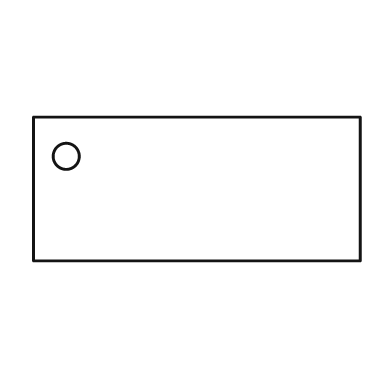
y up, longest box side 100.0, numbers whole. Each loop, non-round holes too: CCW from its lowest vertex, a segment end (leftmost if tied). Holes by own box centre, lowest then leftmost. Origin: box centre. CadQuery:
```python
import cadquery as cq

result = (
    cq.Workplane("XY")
    .moveTo(-50.0, -22.0)
    .lineTo(50.0, -22.0)
    .lineTo(50.0, 22.0)
    .lineTo(-50.0, 22.0)
    .close()
    .moveTo(-40.0, 10.0)
    .circle(4.0)
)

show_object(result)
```